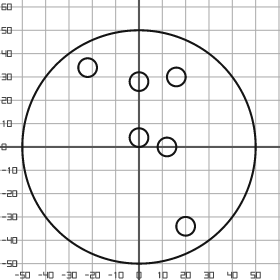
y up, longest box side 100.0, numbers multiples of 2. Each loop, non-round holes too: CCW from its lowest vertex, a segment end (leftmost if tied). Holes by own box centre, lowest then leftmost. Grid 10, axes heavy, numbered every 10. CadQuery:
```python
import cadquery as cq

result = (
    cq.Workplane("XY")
    .moveTo(0.0, 0.0)
    .circle(50.0)
    .moveTo(20.0, -34.0)
    .circle(4.0)
    .moveTo(12.0, 0.0)
    .circle(4.0)
    .moveTo(0.0, 4.0)
    .circle(4.0)
    .moveTo(0.0, 28.0)
    .circle(4.0)
    .moveTo(16.0, 30.0)
    .circle(4.0)
    .moveTo(-22.0, 34.0)
    .circle(4.0)
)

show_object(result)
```